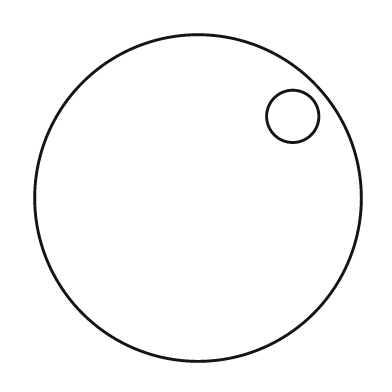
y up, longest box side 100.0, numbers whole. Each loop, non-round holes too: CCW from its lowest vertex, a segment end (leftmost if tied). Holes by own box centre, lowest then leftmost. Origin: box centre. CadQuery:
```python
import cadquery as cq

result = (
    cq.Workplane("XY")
    .moveTo(0.0, 0.0)
    .circle(50.0)
    .moveTo(29.0, 25.0)
    .circle(8.0)
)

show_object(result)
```